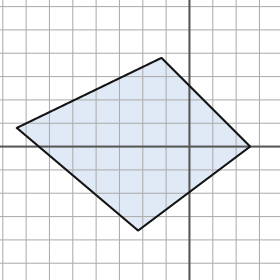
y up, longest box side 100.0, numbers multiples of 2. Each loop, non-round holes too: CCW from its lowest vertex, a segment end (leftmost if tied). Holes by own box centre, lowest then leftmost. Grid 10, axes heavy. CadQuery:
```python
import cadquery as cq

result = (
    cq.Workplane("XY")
    .moveTo(-22.0, -36.0)
    .lineTo(26.0, 0.0)
    .lineTo(-12.0, 38.0)
    .lineTo(-74.0, 8.0)
    .close()
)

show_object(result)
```